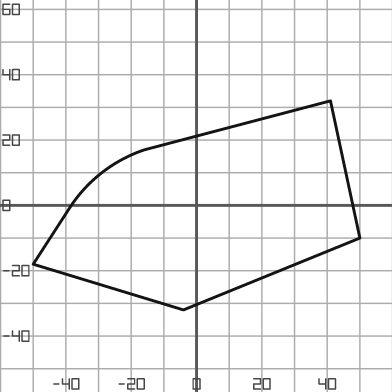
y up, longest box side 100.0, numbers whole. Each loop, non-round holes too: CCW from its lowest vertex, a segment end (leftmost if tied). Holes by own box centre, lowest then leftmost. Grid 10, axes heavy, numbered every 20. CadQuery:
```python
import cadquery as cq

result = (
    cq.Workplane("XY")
    .moveTo(-4.0, -32.0)
    .lineTo(50.0, -10.0)
    .lineTo(41.0, 32.0)
    .lineTo(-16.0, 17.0)
    .threePointArc((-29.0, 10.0), (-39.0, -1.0))
    .lineTo(-50.0, -18.0)
    .close()
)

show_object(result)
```